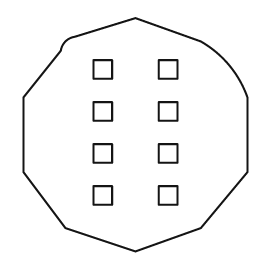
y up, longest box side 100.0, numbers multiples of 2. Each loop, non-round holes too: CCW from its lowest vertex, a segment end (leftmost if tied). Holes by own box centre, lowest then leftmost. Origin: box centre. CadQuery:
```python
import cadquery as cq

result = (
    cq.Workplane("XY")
    .moveTo(0.0, -50.0)
    .lineTo(28.0, -40.0)
    .lineTo(48.0, -16.0)
    .lineTo(48.0, 16.0)
    .threePointArc((40.0, 30.0), (28.0, 40.0))
    .lineTo(0.0, 50.0)
    .lineTo(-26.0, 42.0)
    .threePointArc((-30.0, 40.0), (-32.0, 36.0))
    .lineTo(-48.0, 16.0)
    .lineTo(-48.0, -16.0)
    .lineTo(-30.0, -40.0)
    .close()
    .moveTo(-18.0, -30.0)
    .lineTo(-10.0, -30.0)
    .lineTo(-10.0, -22.0)
    .lineTo(-18.0, -22.0)
    .close()
    .moveTo(10.0, -30.0)
    .lineTo(18.0, -30.0)
    .lineTo(18.0, -22.0)
    .lineTo(10.0, -22.0)
    .close()
    .moveTo(-18.0, -12.0)
    .lineTo(-10.0, -12.0)
    .lineTo(-10.0, -4.0)
    .lineTo(-18.0, -4.0)
    .close()
    .moveTo(10.0, -12.0)
    .lineTo(18.0, -12.0)
    .lineTo(18.0, -4.0)
    .lineTo(10.0, -4.0)
    .close()
    .moveTo(-18.0, 6.0)
    .lineTo(-10.0, 6.0)
    .lineTo(-10.0, 14.0)
    .lineTo(-18.0, 14.0)
    .close()
    .moveTo(10.0, 6.0)
    .lineTo(18.0, 6.0)
    .lineTo(18.0, 14.0)
    .lineTo(10.0, 14.0)
    .close()
    .moveTo(-18.0, 24.0)
    .lineTo(-10.0, 24.0)
    .lineTo(-10.0, 32.0)
    .lineTo(-18.0, 32.0)
    .close()
    .moveTo(10.0, 24.0)
    .lineTo(18.0, 24.0)
    .lineTo(18.0, 32.0)
    .lineTo(10.0, 32.0)
    .close()
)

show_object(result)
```